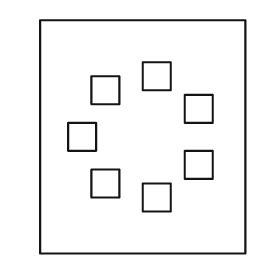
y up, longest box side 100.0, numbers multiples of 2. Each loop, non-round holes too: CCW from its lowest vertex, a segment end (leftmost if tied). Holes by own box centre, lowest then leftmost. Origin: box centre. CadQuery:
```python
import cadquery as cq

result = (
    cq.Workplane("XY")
    .moveTo(-44.0, -50.0)
    .lineTo(44.0, -50.0)
    .lineTo(44.0, 50.0)
    .lineTo(-44.0, 50.0)
    .close()
    .moveTo(0.0, -32.0)
    .lineTo(12.0, -32.0)
    .lineTo(12.0, -20.0)
    .lineTo(0.0, -20.0)
    .close()
    .moveTo(-22.0, -26.0)
    .lineTo(-10.0, -26.0)
    .lineTo(-10.0, -14.0)
    .lineTo(-22.0, -14.0)
    .close()
    .moveTo(18.0, -18.0)
    .lineTo(30.0, -18.0)
    .lineTo(30.0, -6.0)
    .lineTo(18.0, -6.0)
    .close()
    .moveTo(-32.0, -6.0)
    .lineTo(-20.0, -6.0)
    .lineTo(-20.0, 6.0)
    .lineTo(-32.0, 6.0)
    .close()
    .moveTo(18.0, 6.0)
    .lineTo(30.0, 6.0)
    .lineTo(30.0, 18.0)
    .lineTo(18.0, 18.0)
    .close()
    .moveTo(-22.0, 14.0)
    .lineTo(-10.0, 14.0)
    .lineTo(-10.0, 26.0)
    .lineTo(-22.0, 26.0)
    .close()
    .moveTo(0.0, 20.0)
    .lineTo(12.0, 20.0)
    .lineTo(12.0, 32.0)
    .lineTo(0.0, 32.0)
    .close()
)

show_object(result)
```